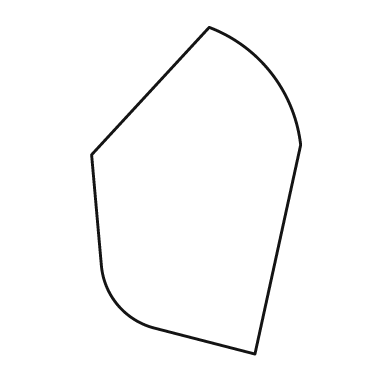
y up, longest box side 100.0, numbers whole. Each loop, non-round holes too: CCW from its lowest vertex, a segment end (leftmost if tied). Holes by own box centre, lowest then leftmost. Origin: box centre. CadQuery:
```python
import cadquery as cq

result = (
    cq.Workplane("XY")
    .moveTo(18.0, -50.0)
    .lineTo(32.0, 14.0)
    .threePointArc((23.0, 36.0), (4.0, 50.0))
    .lineTo(-32.0, 11.0)
    .lineTo(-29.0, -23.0)
    .threePointArc((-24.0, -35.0), (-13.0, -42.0))
    .close()
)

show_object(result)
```